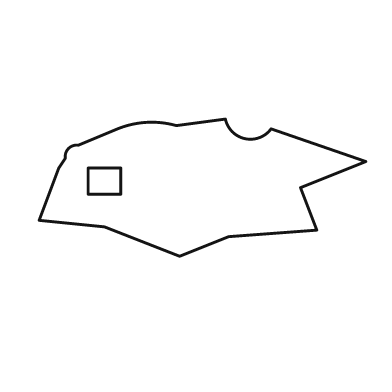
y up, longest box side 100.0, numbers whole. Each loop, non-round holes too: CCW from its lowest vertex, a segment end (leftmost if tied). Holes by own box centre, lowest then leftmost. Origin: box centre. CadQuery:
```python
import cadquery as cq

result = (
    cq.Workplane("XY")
    .moveTo(-7.0, -21.0)
    .lineTo(8.0, -15.0)
    .lineTo(35.0, -13.0)
    .lineTo(30.0, 0.0)
    .lineTo(50.0, 8.0)
    .lineTo(21.0, 18.0)
    .threePointArc((13.0, 15.0), (7.0, 21.0))
    .lineTo(-8.0, 19.0)
    .threePointArc((-17.0, 20.0), (-26.0, 18.0))
    .lineTo(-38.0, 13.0)
    .threePointArc((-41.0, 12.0), (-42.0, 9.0))
    .lineTo(-44.0, 6.0)
    .lineTo(-50.0, -10.0)
    .lineTo(-30.0, -12.0)
    .close()
    .moveTo(-35.0, -2.0)
    .lineTo(-25.0, -2.0)
    .lineTo(-25.0, 6.0)
    .lineTo(-35.0, 6.0)
    .close()
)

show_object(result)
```